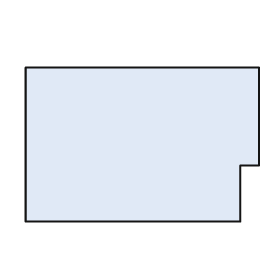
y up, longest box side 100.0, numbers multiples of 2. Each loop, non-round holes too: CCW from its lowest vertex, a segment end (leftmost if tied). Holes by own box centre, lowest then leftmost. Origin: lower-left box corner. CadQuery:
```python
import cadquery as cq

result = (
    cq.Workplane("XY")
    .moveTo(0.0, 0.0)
    .lineTo(92.0, 0.0)
    .lineTo(92.0, 24.0)
    .lineTo(100.0, 24.0)
    .lineTo(100.0, 66.0)
    .lineTo(0.0, 66.0)
    .close()
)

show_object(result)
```